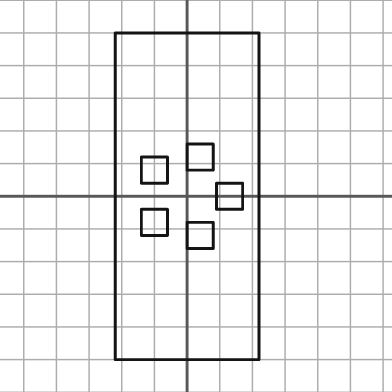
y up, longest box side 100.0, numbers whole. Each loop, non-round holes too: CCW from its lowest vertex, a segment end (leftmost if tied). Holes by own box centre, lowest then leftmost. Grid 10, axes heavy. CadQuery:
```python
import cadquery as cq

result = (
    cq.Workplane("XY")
    .moveTo(-22.0, -50.0)
    .lineTo(22.0, -50.0)
    .lineTo(22.0, 50.0)
    .lineTo(-22.0, 50.0)
    .close()
    .moveTo(0.0, -16.0)
    .lineTo(8.0, -16.0)
    .lineTo(8.0, -8.0)
    .lineTo(0.0, -8.0)
    .close()
    .moveTo(-14.0, -12.0)
    .lineTo(-6.0, -12.0)
    .lineTo(-6.0, -4.0)
    .lineTo(-14.0, -4.0)
    .close()
    .moveTo(9.0, -4.0)
    .lineTo(17.0, -4.0)
    .lineTo(17.0, 4.0)
    .lineTo(9.0, 4.0)
    .close()
    .moveTo(-14.0, 4.0)
    .lineTo(-6.0, 4.0)
    .lineTo(-6.0, 12.0)
    .lineTo(-14.0, 12.0)
    .close()
    .moveTo(0.0, 8.0)
    .lineTo(8.0, 8.0)
    .lineTo(8.0, 16.0)
    .lineTo(0.0, 16.0)
    .close()
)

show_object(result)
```